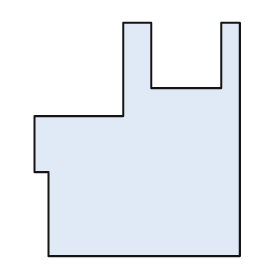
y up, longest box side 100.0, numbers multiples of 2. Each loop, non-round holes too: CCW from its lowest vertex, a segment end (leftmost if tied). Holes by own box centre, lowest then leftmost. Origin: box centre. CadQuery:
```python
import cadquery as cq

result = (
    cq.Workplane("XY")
    .moveTo(-38.0, -50.0)
    .lineTo(44.0, -50.0)
    .lineTo(44.0, 50.0)
    .lineTo(36.0, 50.0)
    .lineTo(36.0, 22.0)
    .lineTo(6.0, 22.0)
    .lineTo(6.0, 50.0)
    .lineTo(-6.0, 50.0)
    .lineTo(-6.0, 10.0)
    .lineTo(-44.0, 10.0)
    .lineTo(-44.0, -14.0)
    .lineTo(-38.0, -14.0)
    .close()
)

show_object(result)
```